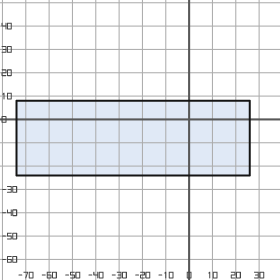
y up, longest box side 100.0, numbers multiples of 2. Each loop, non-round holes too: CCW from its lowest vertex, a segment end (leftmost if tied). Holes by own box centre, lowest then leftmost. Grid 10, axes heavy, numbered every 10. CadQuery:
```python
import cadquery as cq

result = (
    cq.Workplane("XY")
    .moveTo(-74.0, -24.0)
    .lineTo(26.0, -24.0)
    .lineTo(26.0, 8.0)
    .lineTo(-74.0, 8.0)
    .close()
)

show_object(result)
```